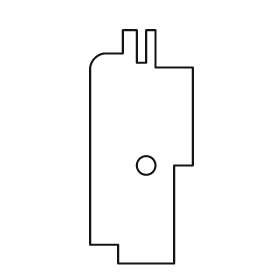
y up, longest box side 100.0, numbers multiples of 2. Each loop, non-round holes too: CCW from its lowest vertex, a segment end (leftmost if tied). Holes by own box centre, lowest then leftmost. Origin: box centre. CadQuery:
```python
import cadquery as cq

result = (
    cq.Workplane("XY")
    .moveTo(-10.0, -50.0)
    .lineTo(14.0, -50.0)
    .lineTo(14.0, -8.0)
    .lineTo(22.0, -8.0)
    .lineTo(22.0, 34.0)
    .lineTo(6.0, 34.0)
    .lineTo(6.0, 50.0)
    .lineTo(2.0, 50.0)
    .lineTo(2.0, 36.0)
    .lineTo(-2.0, 36.0)
    .lineTo(-2.0, 50.0)
    .lineTo(-8.0, 50.0)
    .lineTo(-8.0, 40.0)
    .lineTo(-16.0, 40.0)
    .threePointArc((-20.0, 38.0), (-22.0, 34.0))
    .lineTo(-22.0, -42.0)
    .lineTo(-10.0, -42.0)
    .close()
    .moveTo(2.0, -8.0)
    .circle(4.0)
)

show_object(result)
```